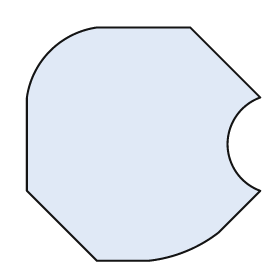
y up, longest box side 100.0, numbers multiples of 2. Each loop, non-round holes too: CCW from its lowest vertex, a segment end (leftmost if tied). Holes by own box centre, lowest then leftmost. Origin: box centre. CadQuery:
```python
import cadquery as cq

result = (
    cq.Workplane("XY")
    .moveTo(-20.0, -50.0)
    .lineTo(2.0, -50.0)
    .threePointArc((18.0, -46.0), (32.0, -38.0))
    .lineTo(50.0, -20.0)
    .threePointArc((36.0, 0.0), (50.0, 20.0))
    .lineTo(20.0, 50.0)
    .lineTo(-20.0, 50.0)
    .threePointArc((-40.0, 40.0), (-50.0, 20.0))
    .lineTo(-50.0, -20.0)
    .close()
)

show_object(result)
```